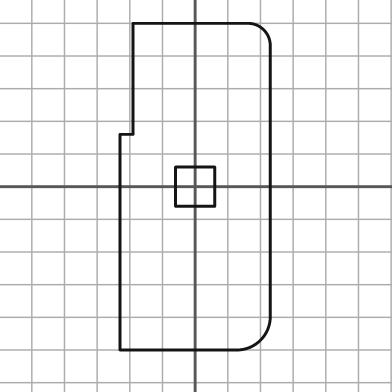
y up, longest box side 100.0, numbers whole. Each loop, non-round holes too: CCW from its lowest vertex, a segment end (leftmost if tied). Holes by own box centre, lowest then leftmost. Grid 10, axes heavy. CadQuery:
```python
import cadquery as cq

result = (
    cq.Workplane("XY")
    .moveTo(-23.0, -50.0)
    .lineTo(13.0, -50.0)
    .threePointArc((20.0, -47.0), (23.0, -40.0))
    .lineTo(23.0, 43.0)
    .threePointArc((21.0, 48.0), (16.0, 50.0))
    .lineTo(-19.0, 50.0)
    .lineTo(-19.0, 16.0)
    .lineTo(-23.0, 16.0)
    .close()
    .moveTo(-6.0, -6.0)
    .lineTo(6.0, -6.0)
    .lineTo(6.0, 6.0)
    .lineTo(-6.0, 6.0)
    .close()
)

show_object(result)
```